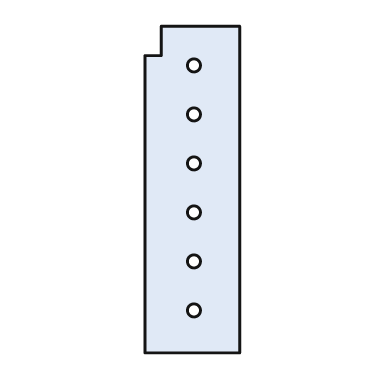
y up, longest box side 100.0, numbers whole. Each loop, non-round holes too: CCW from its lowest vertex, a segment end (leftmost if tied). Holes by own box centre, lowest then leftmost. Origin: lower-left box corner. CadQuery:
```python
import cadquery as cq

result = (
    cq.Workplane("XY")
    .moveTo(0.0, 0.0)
    .lineTo(29.0, 0.0)
    .lineTo(29.0, 100.0)
    .lineTo(5.0, 100.0)
    .lineTo(5.0, 91.0)
    .lineTo(0.0, 91.0)
    .close()
    .moveTo(15.0, 13.0)
    .circle(2.0)
    .moveTo(15.0, 28.0)
    .circle(2.0)
    .moveTo(15.0, 43.0)
    .circle(2.0)
    .moveTo(15.0, 58.0)
    .circle(2.0)
    .moveTo(15.0, 73.0)
    .circle(2.0)
    .moveTo(15.0, 88.0)
    .circle(2.0)
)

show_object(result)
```